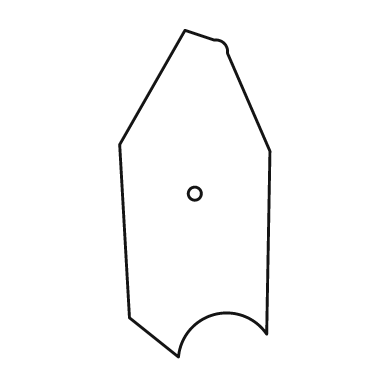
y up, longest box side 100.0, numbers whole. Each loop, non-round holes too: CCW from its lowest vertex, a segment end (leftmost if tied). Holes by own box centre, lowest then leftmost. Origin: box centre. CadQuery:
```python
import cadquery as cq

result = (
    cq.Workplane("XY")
    .moveTo(-5.0, -50.0)
    .threePointArc((6.0, -37.0), (22.0, -43.0))
    .lineTo(23.0, 13.0)
    .lineTo(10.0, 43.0)
    .threePointArc((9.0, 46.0), (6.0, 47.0))
    .lineTo(-3.0, 50.0)
    .lineTo(-23.0, 15.0)
    .lineTo(-20.0, -38.0)
    .close()
    .moveTo(0.0, 0.0)
    .circle(2.0)
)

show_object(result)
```